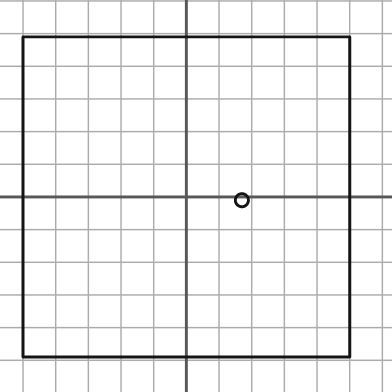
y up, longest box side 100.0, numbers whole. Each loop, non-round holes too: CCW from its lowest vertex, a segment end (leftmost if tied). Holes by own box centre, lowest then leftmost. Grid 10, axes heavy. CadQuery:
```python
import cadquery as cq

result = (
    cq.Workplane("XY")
    .moveTo(-50.0, -49.0)
    .lineTo(50.0, -49.0)
    .lineTo(50.0, 49.0)
    .lineTo(-50.0, 49.0)
    .close()
    .moveTo(17.0, -1.0)
    .circle(2.0)
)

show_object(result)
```